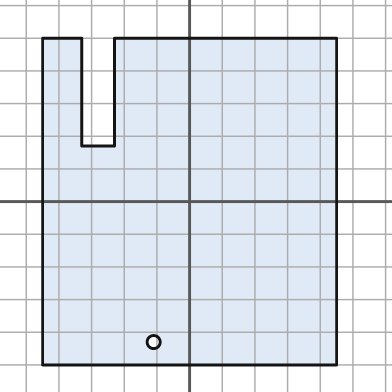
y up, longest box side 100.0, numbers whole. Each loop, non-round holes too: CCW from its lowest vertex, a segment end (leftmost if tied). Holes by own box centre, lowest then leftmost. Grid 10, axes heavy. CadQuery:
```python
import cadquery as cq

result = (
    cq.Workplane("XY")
    .moveTo(-45.0, -50.0)
    .lineTo(45.0, -50.0)
    .lineTo(45.0, 50.0)
    .lineTo(-23.0, 50.0)
    .lineTo(-23.0, 17.0)
    .lineTo(-33.0, 17.0)
    .lineTo(-33.0, 50.0)
    .lineTo(-45.0, 50.0)
    .close()
    .moveTo(-11.0, -43.0)
    .circle(2.0)
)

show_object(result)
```